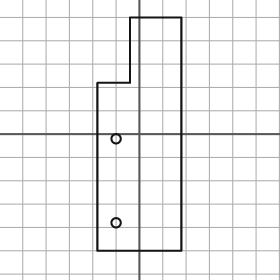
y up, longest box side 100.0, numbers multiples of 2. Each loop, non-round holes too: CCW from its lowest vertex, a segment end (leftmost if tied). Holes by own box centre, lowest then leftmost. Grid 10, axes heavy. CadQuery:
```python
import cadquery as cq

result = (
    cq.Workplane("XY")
    .moveTo(-18.0, -50.0)
    .lineTo(18.0, -50.0)
    .lineTo(18.0, 50.0)
    .lineTo(-4.0, 50.0)
    .lineTo(-4.0, 22.0)
    .lineTo(-18.0, 22.0)
    .close()
    .moveTo(-10.0, -38.0)
    .circle(2.0)
    .moveTo(-10.0, -2.0)
    .circle(2.0)
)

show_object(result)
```